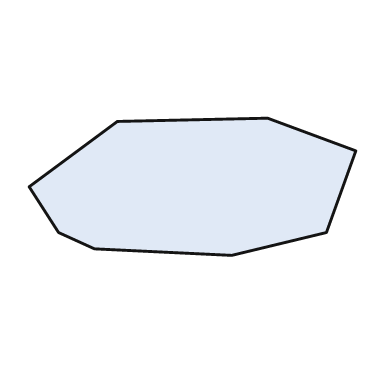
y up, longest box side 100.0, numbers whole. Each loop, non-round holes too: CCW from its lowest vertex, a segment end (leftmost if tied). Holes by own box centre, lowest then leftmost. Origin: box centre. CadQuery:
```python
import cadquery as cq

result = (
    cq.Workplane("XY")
    .moveTo(12.0, -21.0)
    .lineTo(41.0, -14.0)
    .lineTo(50.0, 11.0)
    .lineTo(23.0, 21.0)
    .lineTo(-23.0, 20.0)
    .lineTo(-50.0, 0.0)
    .lineTo(-41.0, -14.0)
    .lineTo(-30.0, -19.0)
    .close()
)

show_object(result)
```